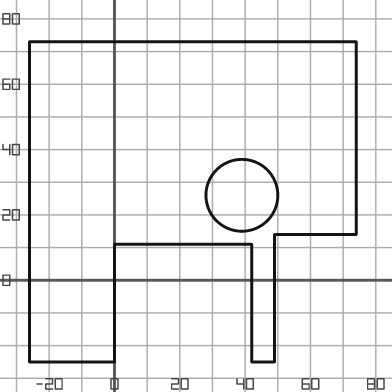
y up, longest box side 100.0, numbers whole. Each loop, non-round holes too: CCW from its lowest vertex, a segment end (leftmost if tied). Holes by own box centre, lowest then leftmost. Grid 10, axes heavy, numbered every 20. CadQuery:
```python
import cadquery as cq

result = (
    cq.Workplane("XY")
    .moveTo(-26.0, -25.0)
    .lineTo(0.0, -25.0)
    .lineTo(0.0, 11.0)
    .lineTo(42.0, 11.0)
    .lineTo(42.0, -25.0)
    .lineTo(49.0, -25.0)
    .lineTo(49.0, 14.0)
    .lineTo(74.0, 14.0)
    .lineTo(74.0, 73.0)
    .lineTo(-26.0, 73.0)
    .close()
    .moveTo(39.0, 26.0)
    .circle(11.0)
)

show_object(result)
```